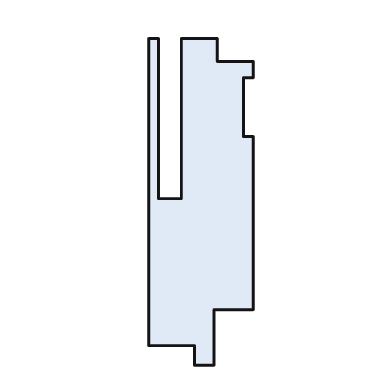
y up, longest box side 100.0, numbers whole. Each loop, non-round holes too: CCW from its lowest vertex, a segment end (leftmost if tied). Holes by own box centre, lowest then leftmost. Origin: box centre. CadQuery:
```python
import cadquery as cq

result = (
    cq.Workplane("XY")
    .moveTo(-2.0, -50.0)
    .lineTo(4.0, -50.0)
    .lineTo(4.0, -33.0)
    .lineTo(16.0, -33.0)
    .lineTo(16.0, 20.0)
    .lineTo(13.0, 20.0)
    .lineTo(13.0, 38.0)
    .lineTo(16.0, 38.0)
    .lineTo(16.0, 43.0)
    .lineTo(5.0, 43.0)
    .lineTo(5.0, 50.0)
    .lineTo(-6.0, 50.0)
    .lineTo(-6.0, 1.0)
    .lineTo(-13.0, 1.0)
    .lineTo(-13.0, 50.0)
    .lineTo(-16.0, 50.0)
    .lineTo(-16.0, -44.0)
    .lineTo(-2.0, -44.0)
    .close()
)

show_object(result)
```